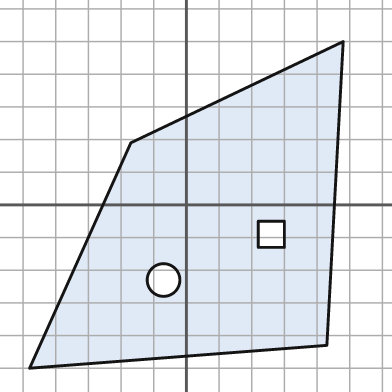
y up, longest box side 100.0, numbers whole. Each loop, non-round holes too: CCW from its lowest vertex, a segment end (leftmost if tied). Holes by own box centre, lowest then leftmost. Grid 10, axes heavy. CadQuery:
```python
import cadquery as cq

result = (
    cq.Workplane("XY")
    .moveTo(-48.0, -50.0)
    .lineTo(43.0, -43.0)
    .lineTo(48.0, 50.0)
    .lineTo(-17.0, 19.0)
    .close()
    .moveTo(-7.0, -23.0)
    .circle(5.0)
    .moveTo(22.0, -13.0)
    .lineTo(30.0, -13.0)
    .lineTo(30.0, -5.0)
    .lineTo(22.0, -5.0)
    .close()
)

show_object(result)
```